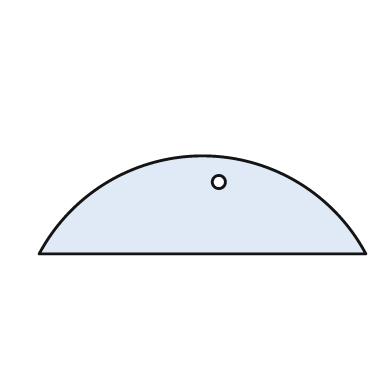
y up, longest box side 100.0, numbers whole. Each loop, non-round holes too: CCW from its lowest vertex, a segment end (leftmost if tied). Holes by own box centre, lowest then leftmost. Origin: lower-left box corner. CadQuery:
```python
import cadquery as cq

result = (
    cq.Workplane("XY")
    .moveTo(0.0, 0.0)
    .lineTo(100.0, 0.0)
    .threePointArc((50.0, 30.0), (0.0, 0.0))
    .close()
    .moveTo(55.0, 22.0)
    .circle(2.0)
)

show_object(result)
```